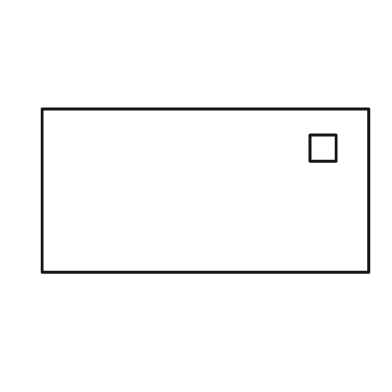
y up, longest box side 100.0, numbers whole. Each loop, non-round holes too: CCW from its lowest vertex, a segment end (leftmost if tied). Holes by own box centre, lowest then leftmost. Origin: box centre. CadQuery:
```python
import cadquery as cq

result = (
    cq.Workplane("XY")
    .moveTo(-50.0, -25.0)
    .lineTo(50.0, -25.0)
    .lineTo(50.0, 25.0)
    .lineTo(-50.0, 25.0)
    .close()
    .moveTo(32.0, 9.0)
    .lineTo(40.0, 9.0)
    .lineTo(40.0, 17.0)
    .lineTo(32.0, 17.0)
    .close()
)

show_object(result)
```